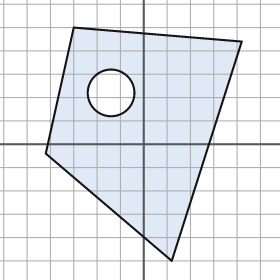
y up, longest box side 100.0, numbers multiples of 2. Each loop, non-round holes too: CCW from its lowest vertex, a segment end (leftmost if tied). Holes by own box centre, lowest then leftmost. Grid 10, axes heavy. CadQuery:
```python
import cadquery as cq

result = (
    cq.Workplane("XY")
    .moveTo(12.0, -50.0)
    .lineTo(42.0, 44.0)
    .lineTo(-30.0, 50.0)
    .lineTo(-42.0, -4.0)
    .close()
    .moveTo(-14.0, 22.0)
    .circle(10.0)
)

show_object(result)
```